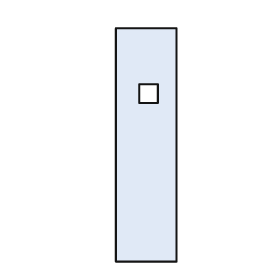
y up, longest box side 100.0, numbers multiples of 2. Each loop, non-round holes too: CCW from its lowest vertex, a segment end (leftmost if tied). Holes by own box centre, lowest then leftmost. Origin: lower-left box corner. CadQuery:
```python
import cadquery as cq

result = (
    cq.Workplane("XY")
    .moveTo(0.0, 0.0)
    .lineTo(26.0, 0.0)
    .lineTo(26.0, 100.0)
    .lineTo(0.0, 100.0)
    .close()
    .moveTo(10.0, 68.0)
    .lineTo(18.0, 68.0)
    .lineTo(18.0, 76.0)
    .lineTo(10.0, 76.0)
    .close()
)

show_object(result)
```